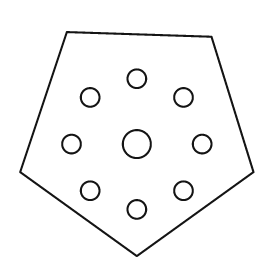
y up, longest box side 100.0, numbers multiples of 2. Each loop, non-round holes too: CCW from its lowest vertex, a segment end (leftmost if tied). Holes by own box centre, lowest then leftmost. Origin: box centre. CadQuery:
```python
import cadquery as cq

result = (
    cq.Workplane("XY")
    .moveTo(0.0, -48.0)
    .lineTo(50.0, -12.0)
    .lineTo(32.0, 46.0)
    .lineTo(-30.0, 48.0)
    .lineTo(-50.0, -12.0)
    .close()
    .moveTo(0.0, -28.0)
    .circle(4.0)
    .moveTo(-20.0, -20.0)
    .circle(4.0)
    .moveTo(20.0, -20.0)
    .circle(4.0)
    .moveTo(-28.0, 0.0)
    .circle(4.0)
    .moveTo(0.0, 0.0)
    .circle(6.0)
    .moveTo(28.0, 0.0)
    .circle(4.0)
    .moveTo(-20.0, 20.0)
    .circle(4.0)
    .moveTo(20.0, 20.0)
    .circle(4.0)
    .moveTo(0.0, 28.0)
    .circle(4.0)
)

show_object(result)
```